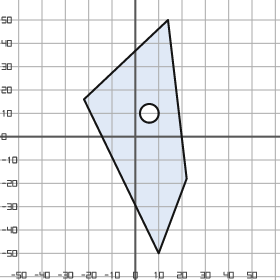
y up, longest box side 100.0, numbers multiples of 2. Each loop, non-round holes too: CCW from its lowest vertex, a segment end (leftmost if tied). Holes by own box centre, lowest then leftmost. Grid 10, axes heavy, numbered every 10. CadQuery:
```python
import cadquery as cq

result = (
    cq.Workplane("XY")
    .moveTo(10.0, -50.0)
    .lineTo(22.0, -18.0)
    .lineTo(14.0, 50.0)
    .lineTo(-22.0, 16.0)
    .close()
    .moveTo(6.0, 10.0)
    .circle(4.0)
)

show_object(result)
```